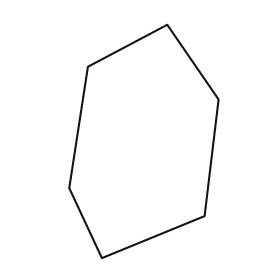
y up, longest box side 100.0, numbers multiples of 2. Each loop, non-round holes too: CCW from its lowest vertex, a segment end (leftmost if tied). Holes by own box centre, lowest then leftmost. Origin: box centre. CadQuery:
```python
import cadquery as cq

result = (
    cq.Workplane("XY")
    .moveTo(-18.0, -50.0)
    .lineTo(26.0, -32.0)
    .lineTo(32.0, 18.0)
    .lineTo(10.0, 50.0)
    .lineTo(-24.0, 32.0)
    .lineTo(-32.0, -20.0)
    .close()
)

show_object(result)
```